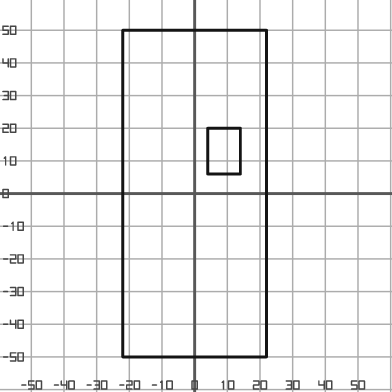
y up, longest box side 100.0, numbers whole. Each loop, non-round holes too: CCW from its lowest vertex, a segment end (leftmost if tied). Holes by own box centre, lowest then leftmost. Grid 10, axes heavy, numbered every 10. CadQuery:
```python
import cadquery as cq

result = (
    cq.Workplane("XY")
    .moveTo(-22.0, -50.0)
    .lineTo(22.0, -50.0)
    .lineTo(22.0, 50.0)
    .lineTo(-22.0, 50.0)
    .close()
    .moveTo(4.0, 6.0)
    .lineTo(14.0, 6.0)
    .lineTo(14.0, 20.0)
    .lineTo(4.0, 20.0)
    .close()
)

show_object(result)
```